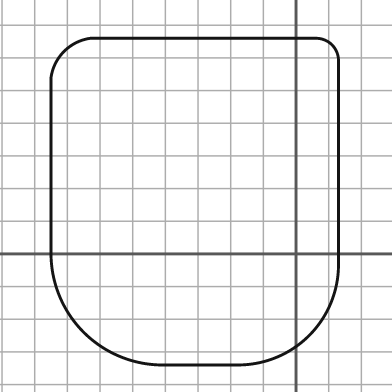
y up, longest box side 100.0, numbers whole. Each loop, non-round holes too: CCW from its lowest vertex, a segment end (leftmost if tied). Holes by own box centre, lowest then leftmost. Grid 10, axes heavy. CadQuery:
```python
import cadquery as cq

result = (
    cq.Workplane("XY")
    .moveTo(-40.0, -34.0)
    .lineTo(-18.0, -34.0)
    .threePointArc((4.0, -25.0), (13.0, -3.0))
    .lineTo(13.0, 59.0)
    .threePointArc((11.0, 64.0), (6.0, 66.0))
    .lineTo(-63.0, 66.0)
    .threePointArc((-71.0, 62.0), (-75.0, 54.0))
    .lineTo(-75.0, 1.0)
    .threePointArc((-65.0, -24.0), (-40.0, -34.0))
    .close()
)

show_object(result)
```